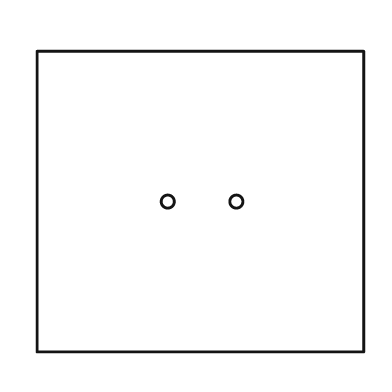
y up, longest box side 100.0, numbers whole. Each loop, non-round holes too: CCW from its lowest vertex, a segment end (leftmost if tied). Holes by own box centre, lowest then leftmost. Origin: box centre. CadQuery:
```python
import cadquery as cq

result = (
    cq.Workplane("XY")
    .moveTo(-50.0, -46.0)
    .lineTo(50.0, -46.0)
    .lineTo(50.0, 46.0)
    .lineTo(-50.0, 46.0)
    .close()
    .moveTo(-10.0, 0.0)
    .circle(2.0)
    .moveTo(11.0, 0.0)
    .circle(2.0)
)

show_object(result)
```